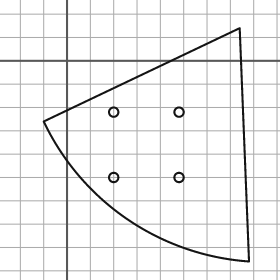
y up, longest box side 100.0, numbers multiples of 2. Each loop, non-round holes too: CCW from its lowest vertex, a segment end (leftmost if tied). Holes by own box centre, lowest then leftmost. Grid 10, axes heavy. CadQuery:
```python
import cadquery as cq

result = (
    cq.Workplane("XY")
    .moveTo(78.0, -86.0)
    .lineTo(74.0, 14.0)
    .lineTo(-10.0, -26.0)
    .threePointArc((26.0, -68.0), (78.0, -86.0))
    .close()
    .moveTo(20.0, -50.0)
    .circle(2.0)
    .moveTo(48.0, -50.0)
    .circle(2.0)
    .moveTo(20.0, -22.0)
    .circle(2.0)
    .moveTo(48.0, -22.0)
    .circle(2.0)
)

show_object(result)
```